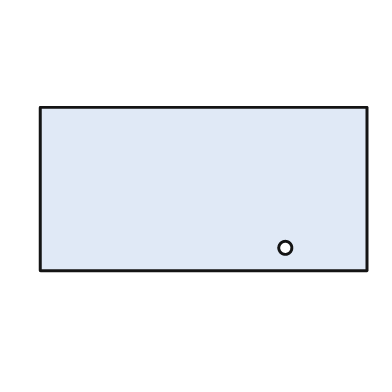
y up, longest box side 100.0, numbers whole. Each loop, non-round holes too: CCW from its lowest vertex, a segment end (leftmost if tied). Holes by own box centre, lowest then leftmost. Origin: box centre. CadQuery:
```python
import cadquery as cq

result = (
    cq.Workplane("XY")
    .moveTo(-50.0, -25.0)
    .lineTo(50.0, -25.0)
    .lineTo(50.0, 25.0)
    .lineTo(-50.0, 25.0)
    .close()
    .moveTo(25.0, -18.0)
    .circle(2.0)
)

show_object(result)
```